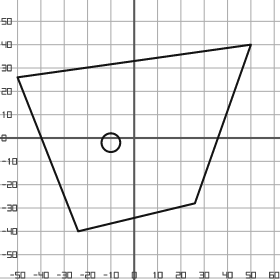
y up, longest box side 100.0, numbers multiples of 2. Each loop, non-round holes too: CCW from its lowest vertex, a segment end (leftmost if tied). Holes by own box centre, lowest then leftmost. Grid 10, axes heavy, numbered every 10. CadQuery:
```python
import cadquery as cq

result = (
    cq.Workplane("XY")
    .moveTo(-24.0, -40.0)
    .lineTo(26.0, -28.0)
    .lineTo(50.0, 40.0)
    .lineTo(-50.0, 26.0)
    .close()
    .moveTo(-10.0, -2.0)
    .circle(4.0)
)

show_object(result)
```